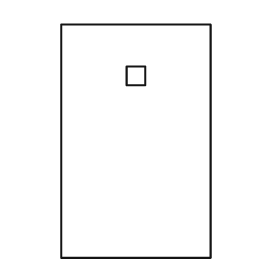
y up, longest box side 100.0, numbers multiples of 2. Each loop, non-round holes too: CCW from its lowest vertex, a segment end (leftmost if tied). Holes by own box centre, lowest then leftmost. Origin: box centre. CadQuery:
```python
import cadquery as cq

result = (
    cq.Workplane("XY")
    .moveTo(-32.0, -50.0)
    .lineTo(32.0, -50.0)
    .lineTo(32.0, 50.0)
    .lineTo(-32.0, 50.0)
    .close()
    .moveTo(-4.0, 24.0)
    .lineTo(4.0, 24.0)
    .lineTo(4.0, 32.0)
    .lineTo(-4.0, 32.0)
    .close()
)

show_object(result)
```